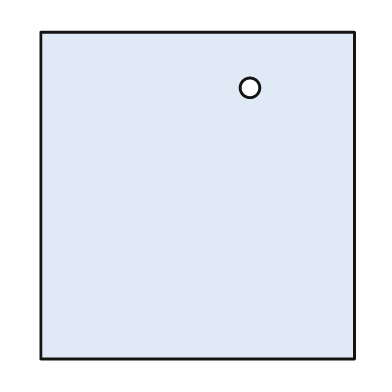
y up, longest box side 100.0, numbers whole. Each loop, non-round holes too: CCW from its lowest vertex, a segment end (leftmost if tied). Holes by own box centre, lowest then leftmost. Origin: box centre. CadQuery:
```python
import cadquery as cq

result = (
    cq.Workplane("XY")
    .moveTo(-48.0, -50.0)
    .lineTo(48.0, -50.0)
    .lineTo(48.0, 50.0)
    .lineTo(-48.0, 50.0)
    .close()
    .moveTo(16.0, 33.0)
    .circle(3.0)
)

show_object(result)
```